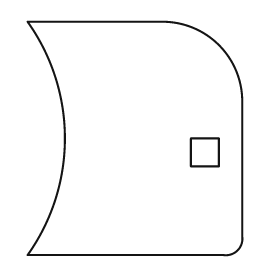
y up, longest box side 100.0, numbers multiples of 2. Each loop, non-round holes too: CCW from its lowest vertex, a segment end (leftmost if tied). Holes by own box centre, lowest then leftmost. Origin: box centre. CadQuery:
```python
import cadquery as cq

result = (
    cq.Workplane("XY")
    .moveTo(-46.0, -50.0)
    .lineTo(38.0, -50.0)
    .threePointArc((44.0, -48.0), (46.0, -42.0))
    .lineTo(46.0, 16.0)
    .threePointArc((36.0, 40.0), (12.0, 50.0))
    .lineTo(-46.0, 50.0)
    .threePointArc((-30.0, 0.0), (-46.0, -50.0))
    .close()
    .moveTo(24.0, -12.0)
    .lineTo(36.0, -12.0)
    .lineTo(36.0, 0.0)
    .lineTo(24.0, 0.0)
    .close()
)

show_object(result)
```